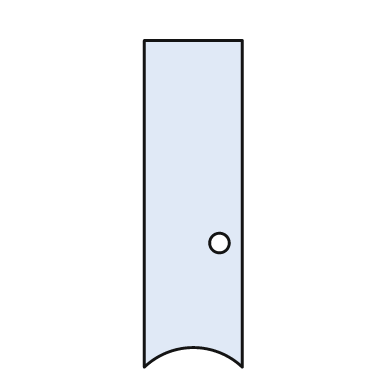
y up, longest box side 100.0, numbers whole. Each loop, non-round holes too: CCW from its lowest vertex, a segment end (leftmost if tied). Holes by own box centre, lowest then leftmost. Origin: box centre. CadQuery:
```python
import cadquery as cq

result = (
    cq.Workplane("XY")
    .moveTo(-15.0, -50.0)
    .threePointArc((0.0, -44.0), (15.0, -50.0))
    .lineTo(15.0, 50.0)
    .lineTo(-15.0, 50.0)
    .close()
    .moveTo(8.0, -12.0)
    .circle(3.0)
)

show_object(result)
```